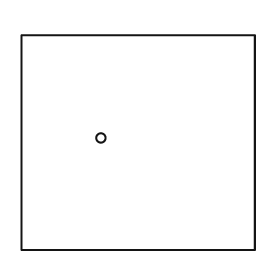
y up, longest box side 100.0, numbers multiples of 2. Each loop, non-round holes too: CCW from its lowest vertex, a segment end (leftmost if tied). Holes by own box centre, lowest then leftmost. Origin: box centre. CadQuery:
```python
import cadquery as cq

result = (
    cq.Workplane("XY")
    .moveTo(-50.0, -46.0)
    .lineTo(50.0, -46.0)
    .lineTo(50.0, 46.0)
    .lineTo(-50.0, 46.0)
    .close()
    .moveTo(-16.0, 2.0)
    .circle(2.0)
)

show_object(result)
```